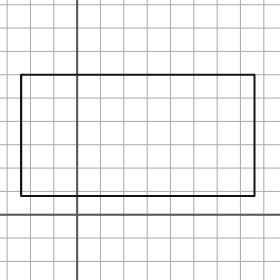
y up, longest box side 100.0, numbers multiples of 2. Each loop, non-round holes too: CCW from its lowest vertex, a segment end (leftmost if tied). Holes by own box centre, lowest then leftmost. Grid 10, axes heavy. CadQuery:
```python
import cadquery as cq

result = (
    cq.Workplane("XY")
    .moveTo(-24.0, 8.0)
    .lineTo(76.0, 8.0)
    .lineTo(76.0, 60.0)
    .lineTo(-24.0, 60.0)
    .close()
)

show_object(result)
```